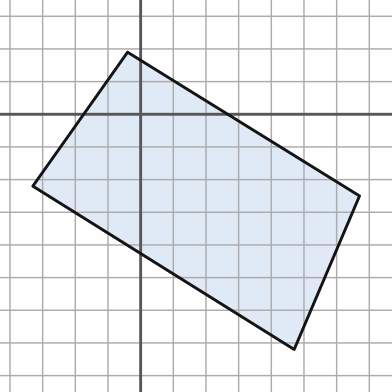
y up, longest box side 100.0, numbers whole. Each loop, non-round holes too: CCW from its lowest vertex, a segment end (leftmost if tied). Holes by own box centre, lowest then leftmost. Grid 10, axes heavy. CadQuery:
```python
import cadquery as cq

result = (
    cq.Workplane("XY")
    .moveTo(47.0, -72.0)
    .lineTo(67.0, -25.0)
    .lineTo(-4.0, 19.0)
    .lineTo(-33.0, -22.0)
    .close()
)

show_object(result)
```